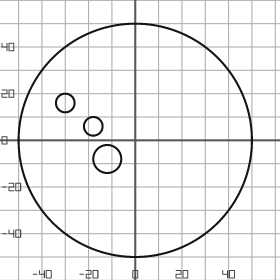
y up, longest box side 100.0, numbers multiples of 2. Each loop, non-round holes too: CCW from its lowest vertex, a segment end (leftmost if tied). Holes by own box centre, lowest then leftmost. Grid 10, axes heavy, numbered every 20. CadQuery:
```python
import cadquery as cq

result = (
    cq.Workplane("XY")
    .moveTo(0.0, 0.0)
    .circle(50.0)
    .moveTo(-12.0, -8.0)
    .circle(6.0)
    .moveTo(-18.0, 6.0)
    .circle(4.0)
    .moveTo(-30.0, 16.0)
    .circle(4.0)
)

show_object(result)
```